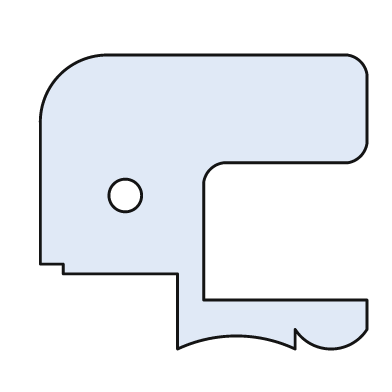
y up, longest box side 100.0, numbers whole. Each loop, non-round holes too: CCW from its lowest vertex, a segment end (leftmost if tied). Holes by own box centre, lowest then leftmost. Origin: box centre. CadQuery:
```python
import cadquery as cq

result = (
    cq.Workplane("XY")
    .moveTo(-8.0, -45.0)
    .threePointArc((10.0, -41.0), (28.0, -45.0))
    .lineTo(28.0, -39.0)
    .threePointArc((39.0, -45.0), (50.0, -39.0))
    .lineTo(50.0, -30.0)
    .lineTo(0.0, -30.0)
    .lineTo(0.0, 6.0)
    .threePointArc((2.0, 10.0), (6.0, 12.0))
    .lineTo(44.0, 12.0)
    .threePointArc((48.0, 14.0), (50.0, 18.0))
    .lineTo(50.0, 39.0)
    .threePointArc((48.0, 43.0), (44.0, 45.0))
    .lineTo(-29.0, 45.0)
    .threePointArc((-44.0, 39.0), (-50.0, 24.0))
    .lineTo(-50.0, -19.0)
    .lineTo(-43.0, -19.0)
    .lineTo(-43.0, -22.0)
    .lineTo(-8.0, -22.0)
    .close()
    .moveTo(-24.0, 2.0)
    .circle(5.0)
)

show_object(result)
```